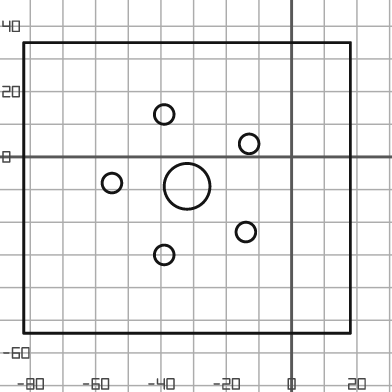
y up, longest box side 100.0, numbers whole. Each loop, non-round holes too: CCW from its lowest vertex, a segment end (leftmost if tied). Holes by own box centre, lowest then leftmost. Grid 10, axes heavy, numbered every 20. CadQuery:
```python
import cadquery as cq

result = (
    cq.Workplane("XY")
    .moveTo(-82.0, -54.0)
    .lineTo(18.0, -54.0)
    .lineTo(18.0, 35.0)
    .lineTo(-82.0, 35.0)
    .close()
    .moveTo(-39.0, -30.0)
    .circle(3.0)
    .moveTo(-14.0, -23.0)
    .circle(3.0)
    .moveTo(-32.0, -9.0)
    .circle(7.0)
    .moveTo(-55.0, -8.0)
    .circle(3.0)
    .moveTo(-13.0, 4.0)
    .circle(3.0)
    .moveTo(-39.0, 13.0)
    .circle(3.0)
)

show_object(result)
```